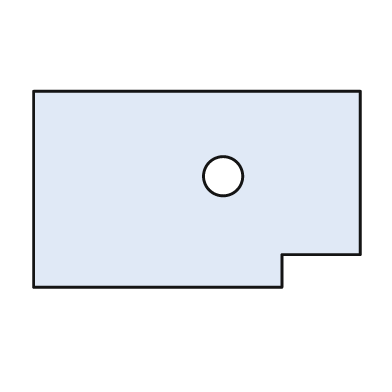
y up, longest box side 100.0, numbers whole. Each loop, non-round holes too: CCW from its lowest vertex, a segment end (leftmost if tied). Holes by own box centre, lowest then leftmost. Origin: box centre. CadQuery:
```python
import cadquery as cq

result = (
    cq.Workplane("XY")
    .moveTo(-50.0, -30.0)
    .lineTo(26.0, -30.0)
    .lineTo(26.0, -20.0)
    .lineTo(50.0, -20.0)
    .lineTo(50.0, 30.0)
    .lineTo(-50.0, 30.0)
    .close()
    .moveTo(8.0, 4.0)
    .circle(6.0)
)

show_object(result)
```